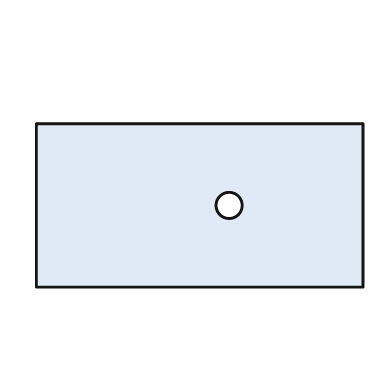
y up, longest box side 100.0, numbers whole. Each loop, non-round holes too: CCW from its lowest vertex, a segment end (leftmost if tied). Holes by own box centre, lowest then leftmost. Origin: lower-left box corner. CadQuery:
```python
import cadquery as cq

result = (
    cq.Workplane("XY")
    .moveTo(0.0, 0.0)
    .lineTo(100.0, 0.0)
    .lineTo(100.0, 50.0)
    .lineTo(0.0, 50.0)
    .close()
    .moveTo(59.0, 25.0)
    .circle(4.0)
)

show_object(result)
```